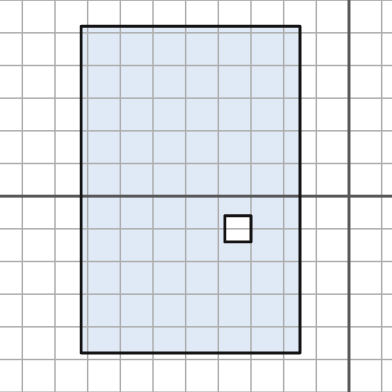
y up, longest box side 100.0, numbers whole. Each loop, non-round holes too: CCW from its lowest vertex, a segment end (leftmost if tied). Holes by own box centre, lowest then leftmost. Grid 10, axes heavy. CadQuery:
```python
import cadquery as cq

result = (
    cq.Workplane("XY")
    .moveTo(-82.0, -48.0)
    .lineTo(-15.0, -48.0)
    .lineTo(-15.0, 52.0)
    .lineTo(-82.0, 52.0)
    .close()
    .moveTo(-38.0, -14.0)
    .lineTo(-30.0, -14.0)
    .lineTo(-30.0, -6.0)
    .lineTo(-38.0, -6.0)
    .close()
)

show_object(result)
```